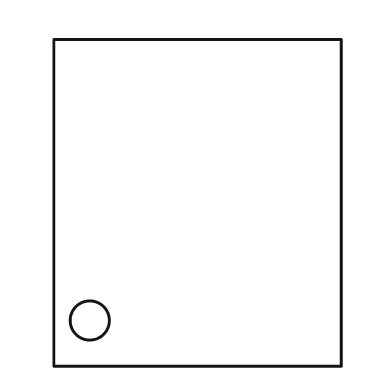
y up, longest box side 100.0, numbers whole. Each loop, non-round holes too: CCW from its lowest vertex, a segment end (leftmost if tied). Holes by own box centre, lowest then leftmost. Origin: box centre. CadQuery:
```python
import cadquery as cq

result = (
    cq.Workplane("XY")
    .moveTo(-44.0, -50.0)
    .lineTo(44.0, -50.0)
    .lineTo(44.0, 50.0)
    .lineTo(-44.0, 50.0)
    .close()
    .moveTo(-33.0, -36.0)
    .circle(6.0)
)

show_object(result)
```